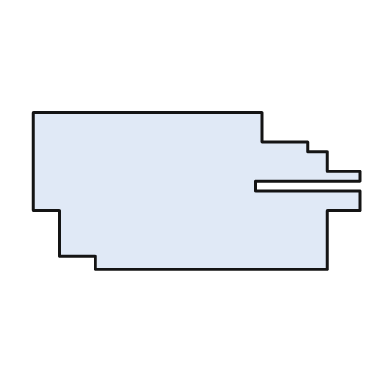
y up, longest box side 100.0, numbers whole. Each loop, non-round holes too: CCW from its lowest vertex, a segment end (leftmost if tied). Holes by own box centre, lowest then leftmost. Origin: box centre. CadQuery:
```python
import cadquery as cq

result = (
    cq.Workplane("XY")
    .moveTo(-31.0, -24.0)
    .lineTo(40.0, -24.0)
    .lineTo(40.0, -6.0)
    .lineTo(50.0, -6.0)
    .lineTo(50.0, 0.0)
    .lineTo(18.0, 0.0)
    .lineTo(18.0, 3.0)
    .lineTo(50.0, 3.0)
    .lineTo(50.0, 6.0)
    .lineTo(40.0, 6.0)
    .lineTo(40.0, 12.0)
    .lineTo(34.0, 12.0)
    .lineTo(34.0, 15.0)
    .lineTo(20.0, 15.0)
    .lineTo(20.0, 24.0)
    .lineTo(-50.0, 24.0)
    .lineTo(-50.0, -6.0)
    .lineTo(-42.0, -6.0)
    .lineTo(-42.0, -20.0)
    .lineTo(-31.0, -20.0)
    .close()
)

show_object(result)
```